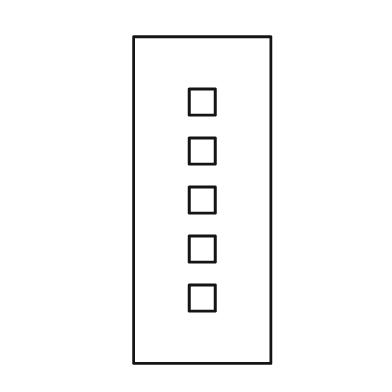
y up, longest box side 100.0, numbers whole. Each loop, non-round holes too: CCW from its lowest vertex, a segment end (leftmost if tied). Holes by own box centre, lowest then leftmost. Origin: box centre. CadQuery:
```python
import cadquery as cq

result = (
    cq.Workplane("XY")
    .moveTo(-21.0, -50.0)
    .lineTo(21.0, -50.0)
    .lineTo(21.0, 50.0)
    .lineTo(-21.0, 50.0)
    .close()
    .moveTo(-4.0, -34.0)
    .lineTo(4.0, -34.0)
    .lineTo(4.0, -26.0)
    .lineTo(-4.0, -26.0)
    .close()
    .moveTo(-4.0, -19.0)
    .lineTo(4.0, -19.0)
    .lineTo(4.0, -11.0)
    .lineTo(-4.0, -11.0)
    .close()
    .moveTo(-4.0, -4.0)
    .lineTo(4.0, -4.0)
    .lineTo(4.0, 4.0)
    .lineTo(-4.0, 4.0)
    .close()
    .moveTo(-4.0, 11.0)
    .lineTo(4.0, 11.0)
    .lineTo(4.0, 19.0)
    .lineTo(-4.0, 19.0)
    .close()
    .moveTo(-4.0, 26.0)
    .lineTo(4.0, 26.0)
    .lineTo(4.0, 34.0)
    .lineTo(-4.0, 34.0)
    .close()
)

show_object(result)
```